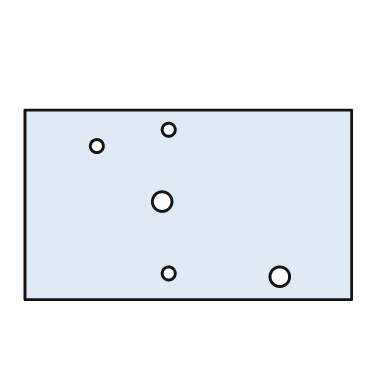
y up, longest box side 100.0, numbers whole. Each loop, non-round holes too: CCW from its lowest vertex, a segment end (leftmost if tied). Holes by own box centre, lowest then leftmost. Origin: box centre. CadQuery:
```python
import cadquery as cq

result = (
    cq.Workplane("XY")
    .moveTo(-50.0, -29.0)
    .lineTo(50.0, -29.0)
    .lineTo(50.0, 29.0)
    .lineTo(-50.0, 29.0)
    .close()
    .moveTo(28.0, -22.0)
    .circle(3.0)
    .moveTo(-6.0, -21.0)
    .circle(2.0)
    .moveTo(-8.0, 1.0)
    .circle(3.0)
    .moveTo(-28.0, 18.0)
    .circle(2.0)
    .moveTo(-6.0, 23.0)
    .circle(2.0)
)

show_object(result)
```